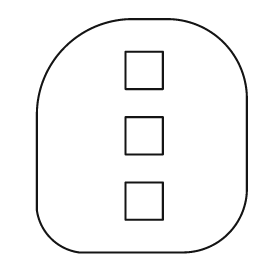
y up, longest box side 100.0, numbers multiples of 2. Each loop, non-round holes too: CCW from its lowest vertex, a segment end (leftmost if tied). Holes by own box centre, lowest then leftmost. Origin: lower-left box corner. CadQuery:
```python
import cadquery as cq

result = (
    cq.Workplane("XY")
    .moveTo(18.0, 0.0)
    .lineTo(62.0, 0.0)
    .threePointArc((82.0, 8.0), (90.0, 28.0))
    .lineTo(90.0, 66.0)
    .threePointArc((80.0, 90.0), (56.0, 100.0))
    .lineTo(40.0, 100.0)
    .threePointArc((12.0, 88.0), (0.0, 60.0))
    .lineTo(0.0, 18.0)
    .threePointArc((6.0, 6.0), (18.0, 0.0))
    .close()
    .moveTo(38.0, 14.0)
    .lineTo(54.0, 14.0)
    .lineTo(54.0, 30.0)
    .lineTo(38.0, 30.0)
    .close()
    .moveTo(38.0, 42.0)
    .lineTo(54.0, 42.0)
    .lineTo(54.0, 58.0)
    .lineTo(38.0, 58.0)
    .close()
    .moveTo(38.0, 70.0)
    .lineTo(54.0, 70.0)
    .lineTo(54.0, 86.0)
    .lineTo(38.0, 86.0)
    .close()
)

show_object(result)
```